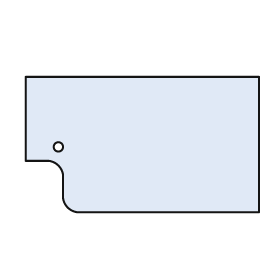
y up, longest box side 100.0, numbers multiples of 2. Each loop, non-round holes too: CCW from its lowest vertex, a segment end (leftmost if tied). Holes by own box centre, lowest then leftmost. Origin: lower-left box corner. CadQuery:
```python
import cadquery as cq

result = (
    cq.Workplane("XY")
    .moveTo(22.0, 0.0)
    .lineTo(100.0, 0.0)
    .lineTo(100.0, 58.0)
    .lineTo(0.0, 58.0)
    .lineTo(0.0, 22.0)
    .lineTo(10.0, 22.0)
    .threePointArc((14.0, 20.0), (16.0, 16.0))
    .lineTo(16.0, 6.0)
    .threePointArc((18.0, 2.0), (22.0, 0.0))
    .close()
    .moveTo(14.0, 28.0)
    .circle(2.0)
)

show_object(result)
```